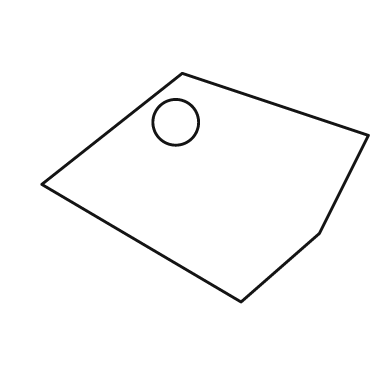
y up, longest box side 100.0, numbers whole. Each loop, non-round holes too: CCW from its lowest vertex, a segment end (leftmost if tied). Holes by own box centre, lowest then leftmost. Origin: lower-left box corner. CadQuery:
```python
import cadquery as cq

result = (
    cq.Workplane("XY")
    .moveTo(61.0, 0.0)
    .lineTo(85.0, 21.0)
    .lineTo(100.0, 51.0)
    .lineTo(43.0, 70.0)
    .lineTo(0.0, 36.0)
    .close()
    .moveTo(41.0, 55.0)
    .circle(7.0)
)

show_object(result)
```